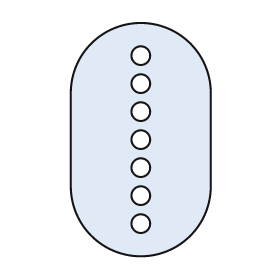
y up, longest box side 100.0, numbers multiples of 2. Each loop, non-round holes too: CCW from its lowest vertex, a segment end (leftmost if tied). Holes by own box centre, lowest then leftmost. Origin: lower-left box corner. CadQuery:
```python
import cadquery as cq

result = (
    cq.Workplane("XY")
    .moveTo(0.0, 30.0)
    .threePointArc((30.0, 0.0), (60.0, 30.0))
    .lineTo(60.0, 70.0)
    .threePointArc((30.0, 100.0), (0.0, 70.0))
    .close()
    .moveTo(30.0, 14.0)
    .circle(4.0)
    .moveTo(30.0, 26.0)
    .circle(4.0)
    .moveTo(30.0, 38.0)
    .circle(4.0)
    .moveTo(30.0, 50.0)
    .circle(4.0)
    .moveTo(30.0, 62.0)
    .circle(4.0)
    .moveTo(30.0, 74.0)
    .circle(4.0)
    .moveTo(30.0, 86.0)
    .circle(4.0)
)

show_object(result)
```